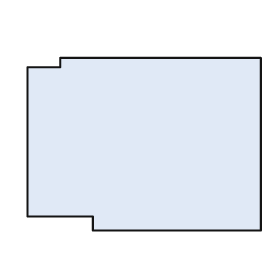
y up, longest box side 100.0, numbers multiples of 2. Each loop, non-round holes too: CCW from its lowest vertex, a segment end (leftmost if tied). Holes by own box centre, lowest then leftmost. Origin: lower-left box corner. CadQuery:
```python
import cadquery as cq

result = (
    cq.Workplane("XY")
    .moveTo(28.0, 0.0)
    .lineTo(100.0, 0.0)
    .lineTo(100.0, 74.0)
    .lineTo(14.0, 74.0)
    .lineTo(14.0, 70.0)
    .lineTo(0.0, 70.0)
    .lineTo(0.0, 6.0)
    .lineTo(28.0, 6.0)
    .close()
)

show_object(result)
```